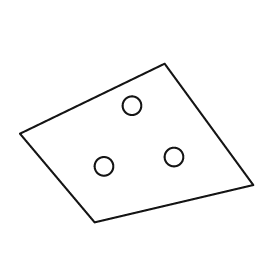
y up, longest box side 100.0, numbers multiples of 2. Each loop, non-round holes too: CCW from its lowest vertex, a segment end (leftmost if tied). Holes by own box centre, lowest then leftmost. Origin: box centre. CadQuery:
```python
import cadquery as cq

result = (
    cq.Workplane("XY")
    .moveTo(-18.0, -34.0)
    .lineTo(50.0, -18.0)
    .lineTo(12.0, 34.0)
    .lineTo(-50.0, 4.0)
    .close()
    .moveTo(-14.0, -10.0)
    .circle(4.0)
    .moveTo(16.0, -6.0)
    .circle(4.0)
    .moveTo(-2.0, 16.0)
    .circle(4.0)
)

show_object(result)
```